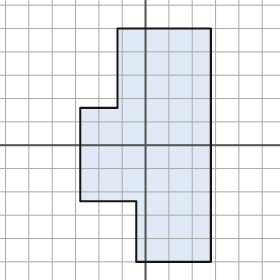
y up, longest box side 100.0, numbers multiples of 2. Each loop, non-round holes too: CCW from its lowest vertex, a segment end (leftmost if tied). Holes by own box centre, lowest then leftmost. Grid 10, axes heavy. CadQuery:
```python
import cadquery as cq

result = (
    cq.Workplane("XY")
    .moveTo(-4.0, -50.0)
    .lineTo(28.0, -50.0)
    .lineTo(28.0, 50.0)
    .lineTo(-12.0, 50.0)
    .lineTo(-12.0, 16.0)
    .lineTo(-28.0, 16.0)
    .lineTo(-28.0, -24.0)
    .lineTo(-4.0, -24.0)
    .close()
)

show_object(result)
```